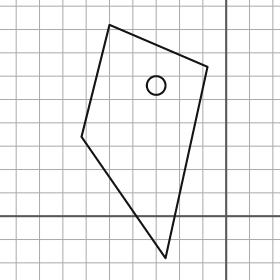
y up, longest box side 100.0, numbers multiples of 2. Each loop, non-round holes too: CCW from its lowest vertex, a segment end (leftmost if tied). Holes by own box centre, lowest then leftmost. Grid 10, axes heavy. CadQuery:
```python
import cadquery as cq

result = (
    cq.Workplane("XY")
    .moveTo(-26.0, -18.0)
    .lineTo(-8.0, 64.0)
    .lineTo(-50.0, 82.0)
    .lineTo(-62.0, 34.0)
    .close()
    .moveTo(-30.0, 56.0)
    .circle(4.0)
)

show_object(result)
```